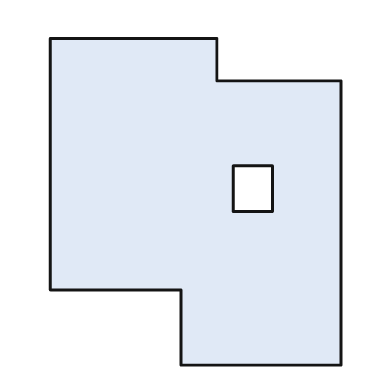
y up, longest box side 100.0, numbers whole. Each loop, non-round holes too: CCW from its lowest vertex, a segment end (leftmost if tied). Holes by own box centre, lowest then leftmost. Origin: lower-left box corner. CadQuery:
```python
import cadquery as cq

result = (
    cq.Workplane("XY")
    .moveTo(40.0, 0.0)
    .lineTo(89.0, 0.0)
    .lineTo(89.0, 87.0)
    .lineTo(51.0, 87.0)
    .lineTo(51.0, 100.0)
    .lineTo(0.0, 100.0)
    .lineTo(0.0, 23.0)
    .lineTo(40.0, 23.0)
    .close()
    .moveTo(56.0, 47.0)
    .lineTo(68.0, 47.0)
    .lineTo(68.0, 61.0)
    .lineTo(56.0, 61.0)
    .close()
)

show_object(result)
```